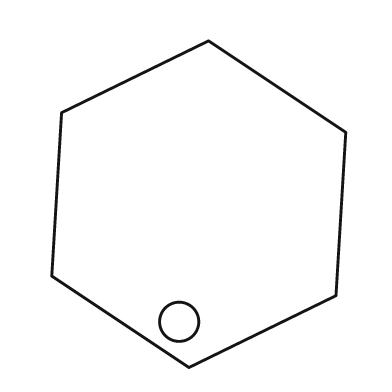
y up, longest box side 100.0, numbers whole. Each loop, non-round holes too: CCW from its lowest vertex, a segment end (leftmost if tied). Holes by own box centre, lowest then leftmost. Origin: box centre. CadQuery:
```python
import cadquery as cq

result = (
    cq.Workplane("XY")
    .moveTo(-3.0, -50.0)
    .lineTo(42.0, -28.0)
    .lineTo(45.0, 22.0)
    .lineTo(3.0, 50.0)
    .lineTo(-42.0, 28.0)
    .lineTo(-45.0, -22.0)
    .close()
    .moveTo(-6.0, -36.0)
    .circle(6.0)
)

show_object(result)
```